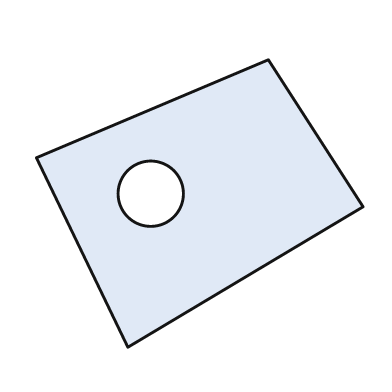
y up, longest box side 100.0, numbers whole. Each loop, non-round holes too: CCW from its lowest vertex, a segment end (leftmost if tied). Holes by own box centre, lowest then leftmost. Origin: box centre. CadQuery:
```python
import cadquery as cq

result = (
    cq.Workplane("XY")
    .moveTo(-22.0, -44.0)
    .lineTo(50.0, -1.0)
    .lineTo(21.0, 44.0)
    .lineTo(-50.0, 14.0)
    .close()
    .moveTo(-15.0, 3.0)
    .circle(10.0)
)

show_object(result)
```